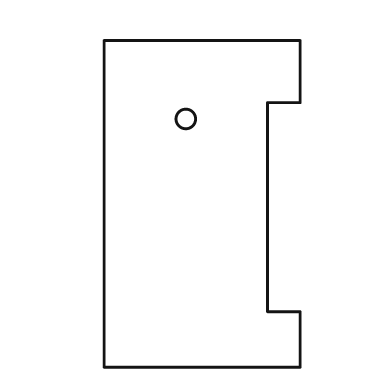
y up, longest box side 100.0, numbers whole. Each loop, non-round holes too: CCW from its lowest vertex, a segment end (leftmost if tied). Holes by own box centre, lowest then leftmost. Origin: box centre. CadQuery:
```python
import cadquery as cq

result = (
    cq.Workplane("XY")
    .moveTo(-30.0, -50.0)
    .lineTo(30.0, -50.0)
    .lineTo(30.0, -33.0)
    .lineTo(20.0, -33.0)
    .lineTo(20.0, 31.0)
    .lineTo(30.0, 31.0)
    .lineTo(30.0, 50.0)
    .lineTo(-30.0, 50.0)
    .close()
    .moveTo(-5.0, 26.0)
    .circle(3.0)
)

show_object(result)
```